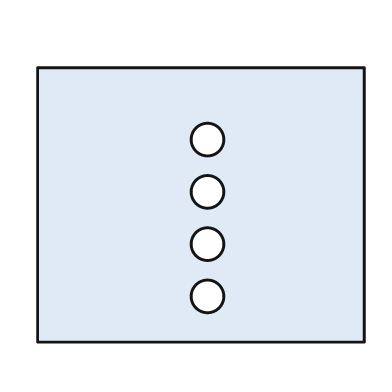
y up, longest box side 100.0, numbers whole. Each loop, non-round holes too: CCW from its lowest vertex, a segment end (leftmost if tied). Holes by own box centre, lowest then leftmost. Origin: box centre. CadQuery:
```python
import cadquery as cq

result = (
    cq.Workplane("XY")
    .moveTo(-50.0, -42.0)
    .lineTo(50.0, -42.0)
    .lineTo(50.0, 42.0)
    .lineTo(-50.0, 42.0)
    .close()
    .moveTo(2.0, -28.0)
    .circle(5.0)
    .moveTo(2.0, -12.0)
    .circle(5.0)
    .moveTo(2.0, 4.0)
    .circle(5.0)
    .moveTo(2.0, 20.0)
    .circle(5.0)
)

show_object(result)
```